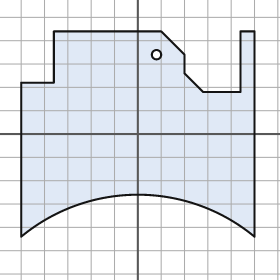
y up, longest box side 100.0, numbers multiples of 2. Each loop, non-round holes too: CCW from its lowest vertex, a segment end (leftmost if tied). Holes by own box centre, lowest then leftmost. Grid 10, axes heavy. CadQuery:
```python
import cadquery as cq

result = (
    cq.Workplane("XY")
    .moveTo(-50.0, -44.0)
    .threePointArc((0.0, -26.0), (50.0, -44.0))
    .lineTo(50.0, 44.0)
    .lineTo(44.0, 44.0)
    .lineTo(44.0, 18.0)
    .lineTo(28.0, 18.0)
    .lineTo(20.0, 26.0)
    .lineTo(20.0, 34.0)
    .lineTo(10.0, 44.0)
    .lineTo(-36.0, 44.0)
    .lineTo(-36.0, 22.0)
    .lineTo(-50.0, 22.0)
    .close()
    .moveTo(8.0, 34.0)
    .circle(2.0)
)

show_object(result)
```